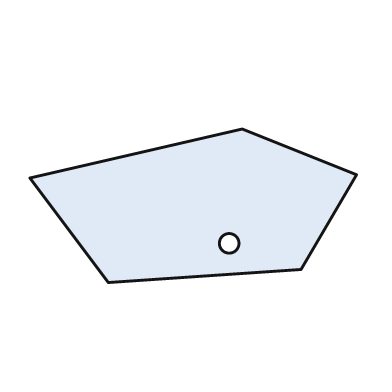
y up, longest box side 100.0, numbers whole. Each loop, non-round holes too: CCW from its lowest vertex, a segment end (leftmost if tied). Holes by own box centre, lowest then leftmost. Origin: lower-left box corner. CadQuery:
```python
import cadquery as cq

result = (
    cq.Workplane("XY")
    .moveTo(24.0, 0.0)
    .lineTo(83.0, 4.0)
    .lineTo(100.0, 33.0)
    .lineTo(65.0, 47.0)
    .lineTo(0.0, 32.0)
    .close()
    .moveTo(61.0, 12.0)
    .circle(3.0)
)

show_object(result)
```